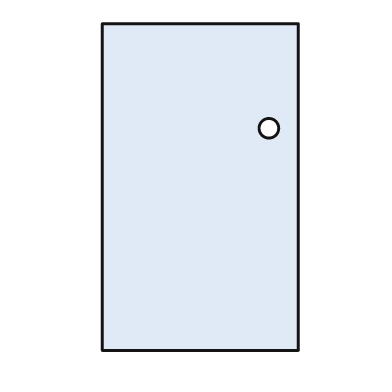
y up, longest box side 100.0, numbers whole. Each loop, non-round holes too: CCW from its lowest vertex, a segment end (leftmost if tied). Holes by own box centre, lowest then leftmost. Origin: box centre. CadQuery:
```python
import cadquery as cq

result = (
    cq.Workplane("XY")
    .moveTo(-30.0, -50.0)
    .lineTo(30.0, -50.0)
    .lineTo(30.0, 50.0)
    .lineTo(-30.0, 50.0)
    .close()
    .moveTo(21.0, 18.0)
    .circle(3.0)
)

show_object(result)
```